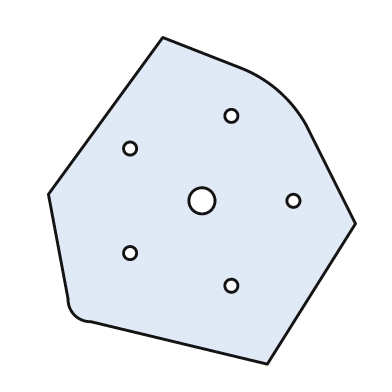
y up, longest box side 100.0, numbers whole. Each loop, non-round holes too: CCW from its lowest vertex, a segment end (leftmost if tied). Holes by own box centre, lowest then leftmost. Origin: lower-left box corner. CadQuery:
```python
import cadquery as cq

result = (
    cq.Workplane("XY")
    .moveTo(67.0, 0.0)
    .lineTo(94.0, 43.0)
    .lineTo(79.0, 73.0)
    .threePointArc((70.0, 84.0), (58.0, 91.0))
    .lineTo(35.0, 100.0)
    .lineTo(0.0, 52.0)
    .lineTo(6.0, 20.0)
    .threePointArc((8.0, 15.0), (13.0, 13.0))
    .close()
    .moveTo(56.0, 24.0)
    .circle(2.0)
    .moveTo(25.0, 34.0)
    .circle(2.0)
    .moveTo(47.0, 50.0)
    .circle(4.0)
    .moveTo(75.0, 50.0)
    .circle(2.0)
    .moveTo(25.0, 66.0)
    .circle(2.0)
    .moveTo(56.0, 76.0)
    .circle(2.0)
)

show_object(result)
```